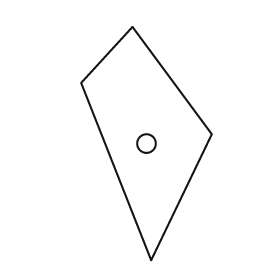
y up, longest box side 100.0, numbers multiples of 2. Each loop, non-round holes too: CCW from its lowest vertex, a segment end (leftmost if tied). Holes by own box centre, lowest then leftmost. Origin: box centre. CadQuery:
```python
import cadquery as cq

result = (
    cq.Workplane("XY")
    .moveTo(2.0, -50.0)
    .lineTo(28.0, 4.0)
    .lineTo(-6.0, 50.0)
    .lineTo(-28.0, 26.0)
    .close()
    .moveTo(0.0, 0.0)
    .circle(4.0)
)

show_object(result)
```